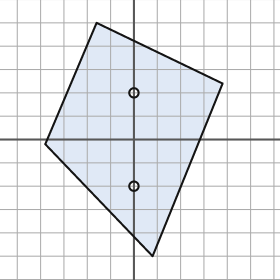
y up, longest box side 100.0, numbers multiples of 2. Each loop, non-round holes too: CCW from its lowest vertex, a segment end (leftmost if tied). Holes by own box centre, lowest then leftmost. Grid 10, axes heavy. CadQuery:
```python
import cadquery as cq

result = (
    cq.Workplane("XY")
    .moveTo(8.0, -50.0)
    .lineTo(38.0, 24.0)
    .lineTo(-16.0, 50.0)
    .lineTo(-38.0, -2.0)
    .close()
    .moveTo(0.0, -20.0)
    .circle(2.0)
    .moveTo(0.0, 20.0)
    .circle(2.0)
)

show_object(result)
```